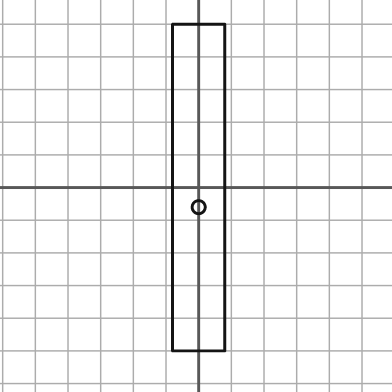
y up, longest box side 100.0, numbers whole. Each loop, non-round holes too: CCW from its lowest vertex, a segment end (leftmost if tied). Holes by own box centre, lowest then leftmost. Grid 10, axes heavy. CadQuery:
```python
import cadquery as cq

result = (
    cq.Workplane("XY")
    .moveTo(-8.0, -50.0)
    .lineTo(8.0, -50.0)
    .lineTo(8.0, 50.0)
    .lineTo(-8.0, 50.0)
    .close()
    .moveTo(0.0, -6.0)
    .circle(2.0)
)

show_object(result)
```